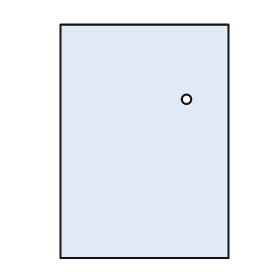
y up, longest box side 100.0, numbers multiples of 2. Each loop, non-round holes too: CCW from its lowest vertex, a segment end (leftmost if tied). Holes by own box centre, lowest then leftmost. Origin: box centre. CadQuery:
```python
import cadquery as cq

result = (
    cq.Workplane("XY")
    .moveTo(-36.0, -50.0)
    .lineTo(36.0, -50.0)
    .lineTo(36.0, 50.0)
    .lineTo(-36.0, 50.0)
    .close()
    .moveTo(18.0, 18.0)
    .circle(2.0)
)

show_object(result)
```